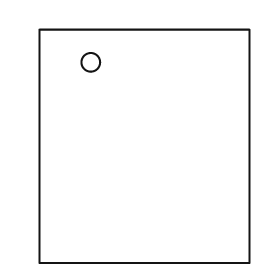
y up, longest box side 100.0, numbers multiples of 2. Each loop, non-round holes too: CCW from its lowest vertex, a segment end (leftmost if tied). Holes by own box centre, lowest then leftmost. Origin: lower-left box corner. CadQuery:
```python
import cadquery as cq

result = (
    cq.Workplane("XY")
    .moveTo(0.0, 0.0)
    .lineTo(90.0, 0.0)
    .lineTo(90.0, 100.0)
    .lineTo(0.0, 100.0)
    .close()
    .moveTo(22.0, 86.0)
    .circle(4.0)
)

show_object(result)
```